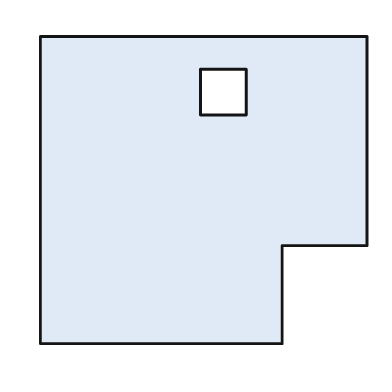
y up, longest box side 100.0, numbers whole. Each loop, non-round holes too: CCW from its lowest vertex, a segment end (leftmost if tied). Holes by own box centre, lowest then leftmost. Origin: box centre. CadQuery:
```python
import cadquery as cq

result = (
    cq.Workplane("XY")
    .moveTo(-50.0, -47.0)
    .lineTo(24.0, -47.0)
    .lineTo(24.0, -17.0)
    .lineTo(50.0, -17.0)
    .lineTo(50.0, 47.0)
    .lineTo(-50.0, 47.0)
    .close()
    .moveTo(-1.0, 23.0)
    .lineTo(13.0, 23.0)
    .lineTo(13.0, 37.0)
    .lineTo(-1.0, 37.0)
    .close()
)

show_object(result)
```